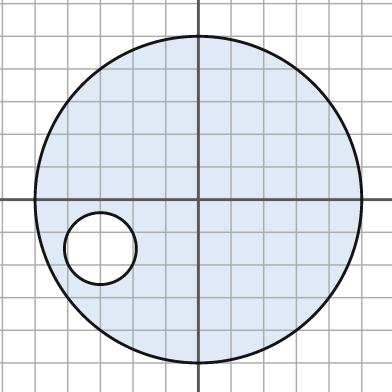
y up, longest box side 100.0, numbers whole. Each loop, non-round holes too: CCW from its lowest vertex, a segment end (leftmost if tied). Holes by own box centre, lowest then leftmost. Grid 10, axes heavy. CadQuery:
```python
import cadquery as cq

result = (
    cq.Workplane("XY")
    .moveTo(0.0, 0.0)
    .circle(50.0)
    .moveTo(-30.0, -15.0)
    .circle(11.0)
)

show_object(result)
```